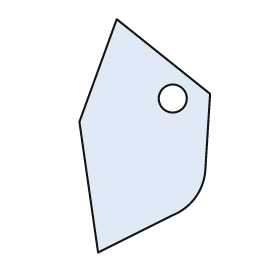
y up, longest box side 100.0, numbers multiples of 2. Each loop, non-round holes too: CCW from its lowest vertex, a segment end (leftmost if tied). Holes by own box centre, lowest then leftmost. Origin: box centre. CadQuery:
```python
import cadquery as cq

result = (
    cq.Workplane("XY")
    .moveTo(-20.0, -50.0)
    .lineTo(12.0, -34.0)
    .threePointArc((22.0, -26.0), (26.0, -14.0))
    .lineTo(28.0, 18.0)
    .lineTo(-12.0, 50.0)
    .lineTo(-28.0, 6.0)
    .close()
    .moveTo(12.0, 16.0)
    .circle(6.0)
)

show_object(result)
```